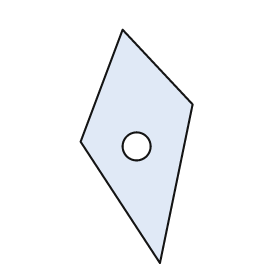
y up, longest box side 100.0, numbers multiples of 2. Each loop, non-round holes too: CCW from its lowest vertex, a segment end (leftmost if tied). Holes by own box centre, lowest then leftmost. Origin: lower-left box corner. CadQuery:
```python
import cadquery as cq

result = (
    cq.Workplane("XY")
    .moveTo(34.0, 0.0)
    .lineTo(48.0, 68.0)
    .lineTo(18.0, 100.0)
    .lineTo(0.0, 52.0)
    .close()
    .moveTo(24.0, 50.0)
    .circle(6.0)
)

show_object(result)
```